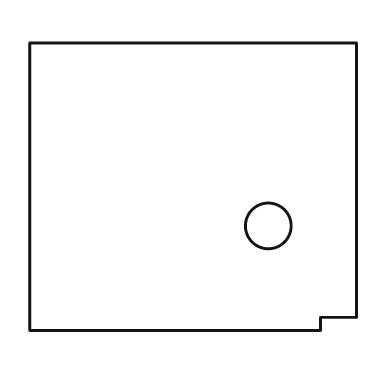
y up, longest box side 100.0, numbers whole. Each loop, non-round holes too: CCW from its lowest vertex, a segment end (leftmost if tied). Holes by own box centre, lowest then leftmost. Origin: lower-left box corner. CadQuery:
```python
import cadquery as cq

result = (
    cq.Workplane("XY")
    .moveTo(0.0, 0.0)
    .lineTo(89.0, 0.0)
    .lineTo(89.0, 4.0)
    .lineTo(100.0, 4.0)
    .lineTo(100.0, 88.0)
    .lineTo(0.0, 88.0)
    .close()
    .moveTo(73.0, 32.0)
    .circle(7.0)
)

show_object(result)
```